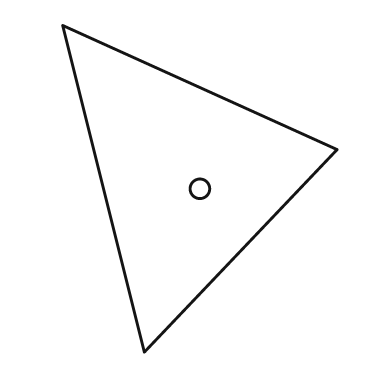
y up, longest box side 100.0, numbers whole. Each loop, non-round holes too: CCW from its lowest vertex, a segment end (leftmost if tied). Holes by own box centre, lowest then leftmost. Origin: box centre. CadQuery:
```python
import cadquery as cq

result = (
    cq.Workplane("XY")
    .moveTo(-17.0, -50.0)
    .lineTo(42.0, 12.0)
    .lineTo(-42.0, 50.0)
    .close()
    .moveTo(0.0, 0.0)
    .circle(3.0)
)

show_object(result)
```